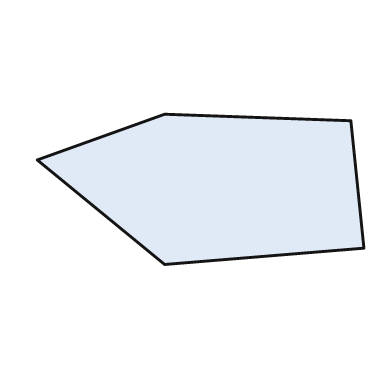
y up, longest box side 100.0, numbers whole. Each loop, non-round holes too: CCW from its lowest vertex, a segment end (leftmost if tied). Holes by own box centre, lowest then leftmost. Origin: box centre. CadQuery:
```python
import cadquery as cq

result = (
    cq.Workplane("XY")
    .moveTo(-11.0, -23.0)
    .lineTo(50.0, -18.0)
    .lineTo(46.0, 21.0)
    .lineTo(-11.0, 23.0)
    .lineTo(-50.0, 9.0)
    .close()
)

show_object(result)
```